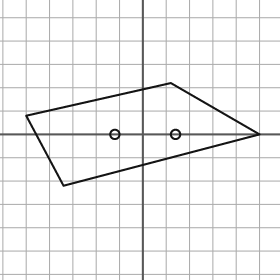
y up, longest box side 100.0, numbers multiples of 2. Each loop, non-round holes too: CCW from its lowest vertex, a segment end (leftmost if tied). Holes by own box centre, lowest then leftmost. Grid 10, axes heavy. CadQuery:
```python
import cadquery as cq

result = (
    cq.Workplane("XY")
    .moveTo(-34.0, -22.0)
    .lineTo(50.0, 0.0)
    .lineTo(12.0, 22.0)
    .lineTo(-50.0, 8.0)
    .close()
    .moveTo(-12.0, 0.0)
    .circle(2.0)
    .moveTo(14.0, 0.0)
    .circle(2.0)
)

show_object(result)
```